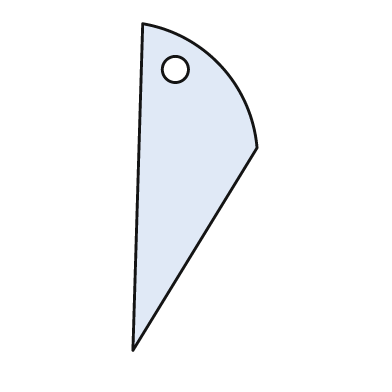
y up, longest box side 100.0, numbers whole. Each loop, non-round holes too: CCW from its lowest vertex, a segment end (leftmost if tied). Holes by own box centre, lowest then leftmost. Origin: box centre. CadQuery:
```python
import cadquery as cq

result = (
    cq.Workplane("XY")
    .moveTo(-19.0, -50.0)
    .lineTo(19.0, 12.0)
    .threePointArc((8.0, 37.0), (-16.0, 50.0))
    .close()
    .moveTo(-6.0, 36.0)
    .circle(4.0)
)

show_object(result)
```